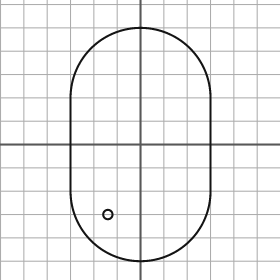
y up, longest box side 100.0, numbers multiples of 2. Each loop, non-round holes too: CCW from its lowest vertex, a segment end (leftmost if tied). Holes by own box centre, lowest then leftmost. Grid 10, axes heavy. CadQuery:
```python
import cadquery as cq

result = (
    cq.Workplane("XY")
    .moveTo(-30.0, -20.0)
    .threePointArc((0.0, -50.0), (30.0, -20.0))
    .lineTo(30.0, 20.0)
    .threePointArc((0.0, 50.0), (-30.0, 20.0))
    .close()
    .moveTo(-14.0, -30.0)
    .circle(2.0)
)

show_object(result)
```